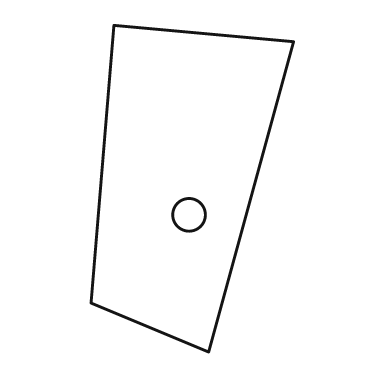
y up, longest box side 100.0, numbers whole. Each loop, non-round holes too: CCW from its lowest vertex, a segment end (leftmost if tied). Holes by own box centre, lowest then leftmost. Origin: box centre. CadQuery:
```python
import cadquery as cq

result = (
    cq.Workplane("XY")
    .moveTo(5.0, -50.0)
    .lineTo(31.0, 45.0)
    .lineTo(-24.0, 50.0)
    .lineTo(-31.0, -35.0)
    .close()
    .moveTo(-1.0, -8.0)
    .circle(5.0)
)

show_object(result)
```